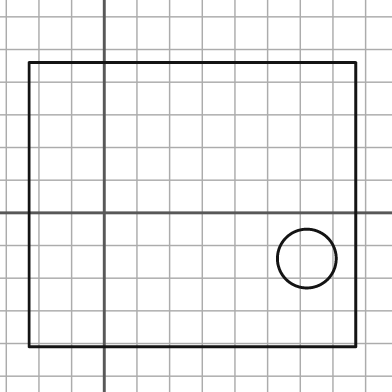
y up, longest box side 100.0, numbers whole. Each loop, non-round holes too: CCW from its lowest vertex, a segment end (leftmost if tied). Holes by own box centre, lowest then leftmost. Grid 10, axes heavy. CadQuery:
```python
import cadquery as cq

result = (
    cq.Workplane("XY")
    .moveTo(-23.0, -41.0)
    .lineTo(77.0, -41.0)
    .lineTo(77.0, 46.0)
    .lineTo(-23.0, 46.0)
    .close()
    .moveTo(62.0, -14.0)
    .circle(9.0)
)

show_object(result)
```